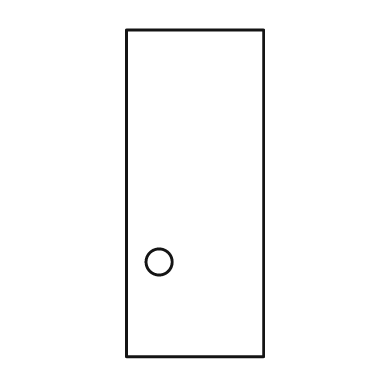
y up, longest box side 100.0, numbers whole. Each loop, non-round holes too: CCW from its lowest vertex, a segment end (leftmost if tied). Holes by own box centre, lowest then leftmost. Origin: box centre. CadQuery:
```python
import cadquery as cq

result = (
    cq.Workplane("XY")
    .moveTo(-21.0, -50.0)
    .lineTo(21.0, -50.0)
    .lineTo(21.0, 50.0)
    .lineTo(-21.0, 50.0)
    .close()
    .moveTo(-11.0, -21.0)
    .circle(4.0)
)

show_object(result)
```